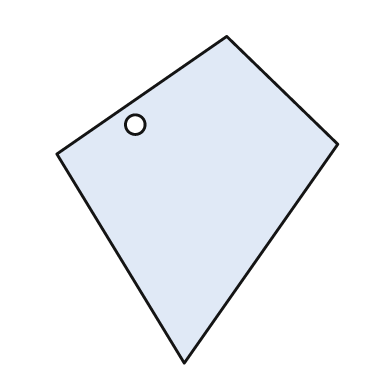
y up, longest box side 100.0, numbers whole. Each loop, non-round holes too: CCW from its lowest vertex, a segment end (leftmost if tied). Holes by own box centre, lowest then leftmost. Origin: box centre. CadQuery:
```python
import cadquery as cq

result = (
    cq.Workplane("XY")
    .moveTo(-4.0, -50.0)
    .lineTo(43.0, 17.0)
    .lineTo(9.0, 50.0)
    .lineTo(-43.0, 14.0)
    .close()
    .moveTo(-19.0, 23.0)
    .circle(3.0)
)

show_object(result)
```